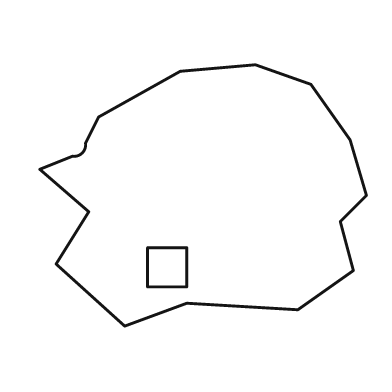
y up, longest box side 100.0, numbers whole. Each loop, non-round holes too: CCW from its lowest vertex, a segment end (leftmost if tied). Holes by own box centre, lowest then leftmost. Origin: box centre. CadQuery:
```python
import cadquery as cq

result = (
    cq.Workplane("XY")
    .moveTo(-24.0, -40.0)
    .lineTo(-5.0, -33.0)
    .lineTo(29.0, -35.0)
    .lineTo(46.0, -23.0)
    .lineTo(42.0, -8.0)
    .lineTo(50.0, 0.0)
    .lineTo(45.0, 17.0)
    .lineTo(33.0, 34.0)
    .lineTo(16.0, 40.0)
    .lineTo(-7.0, 38.0)
    .lineTo(-32.0, 24.0)
    .lineTo(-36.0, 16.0)
    .threePointArc((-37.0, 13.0), (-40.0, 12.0))
    .lineTo(-50.0, 8.0)
    .lineTo(-35.0, -5.0)
    .lineTo(-45.0, -21.0)
    .close()
    .moveTo(-17.0, -28.0)
    .lineTo(-5.0, -28.0)
    .lineTo(-5.0, -16.0)
    .lineTo(-17.0, -16.0)
    .close()
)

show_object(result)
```